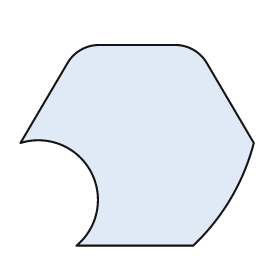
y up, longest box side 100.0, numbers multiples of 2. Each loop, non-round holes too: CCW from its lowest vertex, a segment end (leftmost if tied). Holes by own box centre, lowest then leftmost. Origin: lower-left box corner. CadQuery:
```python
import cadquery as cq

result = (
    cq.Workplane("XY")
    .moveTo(24.0, 0.0)
    .lineTo(74.0, 0.0)
    .threePointArc((90.0, 20.0), (100.0, 44.0))
    .lineTo(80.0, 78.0)
    .threePointArc((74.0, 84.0), (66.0, 86.0))
    .lineTo(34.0, 86.0)
    .threePointArc((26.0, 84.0), (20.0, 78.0))
    .lineTo(0.0, 44.0)
    .threePointArc((30.0, 32.0), (24.0, 0.0))
    .close()
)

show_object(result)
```